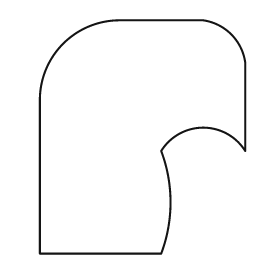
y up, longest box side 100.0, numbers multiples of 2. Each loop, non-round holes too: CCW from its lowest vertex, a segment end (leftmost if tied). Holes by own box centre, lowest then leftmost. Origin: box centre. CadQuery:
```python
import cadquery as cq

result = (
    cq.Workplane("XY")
    .moveTo(-44.0, -50.0)
    .lineTo(8.0, -50.0)
    .threePointArc((12.0, -28.0), (8.0, -6.0))
    .threePointArc((26.0, 4.0), (44.0, -6.0))
    .lineTo(44.0, 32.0)
    .threePointArc((38.0, 44.0), (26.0, 50.0))
    .lineTo(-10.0, 50.0)
    .threePointArc((-34.0, 40.0), (-44.0, 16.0))
    .close()
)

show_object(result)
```